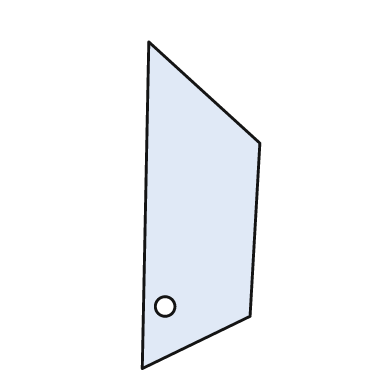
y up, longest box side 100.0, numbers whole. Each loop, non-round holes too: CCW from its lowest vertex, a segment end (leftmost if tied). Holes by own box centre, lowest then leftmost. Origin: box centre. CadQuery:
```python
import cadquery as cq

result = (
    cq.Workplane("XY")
    .moveTo(-18.0, -50.0)
    .lineTo(15.0, -34.0)
    .lineTo(18.0, 19.0)
    .lineTo(-16.0, 50.0)
    .close()
    .moveTo(-11.0, -31.0)
    .circle(3.0)
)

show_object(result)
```